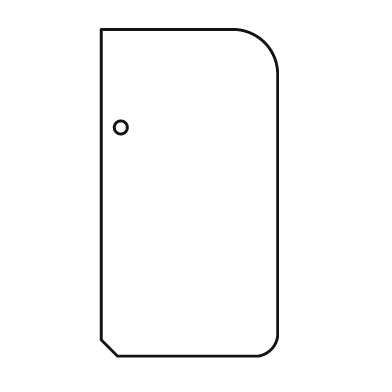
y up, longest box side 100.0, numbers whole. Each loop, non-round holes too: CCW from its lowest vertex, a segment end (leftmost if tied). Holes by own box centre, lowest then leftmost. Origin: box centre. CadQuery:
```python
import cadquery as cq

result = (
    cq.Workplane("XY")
    .moveTo(-22.0, -50.0)
    .lineTo(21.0, -50.0)
    .threePointArc((25.0, -48.0), (27.0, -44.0))
    .lineTo(27.0, 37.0)
    .threePointArc((23.0, 46.0), (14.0, 50.0))
    .lineTo(-27.0, 50.0)
    .lineTo(-27.0, -45.0)
    .close()
    .moveTo(-21.0, 20.0)
    .circle(2.0)
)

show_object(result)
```